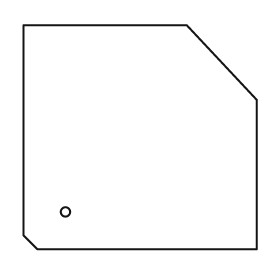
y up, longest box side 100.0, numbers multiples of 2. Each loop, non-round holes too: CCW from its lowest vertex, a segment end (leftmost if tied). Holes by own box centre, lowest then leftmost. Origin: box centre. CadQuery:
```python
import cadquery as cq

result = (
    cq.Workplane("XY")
    .moveTo(-44.0, -48.0)
    .lineTo(50.0, -48.0)
    .lineTo(50.0, 16.0)
    .lineTo(20.0, 48.0)
    .lineTo(-50.0, 48.0)
    .lineTo(-50.0, -42.0)
    .close()
    .moveTo(-32.0, -32.0)
    .circle(2.0)
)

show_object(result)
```